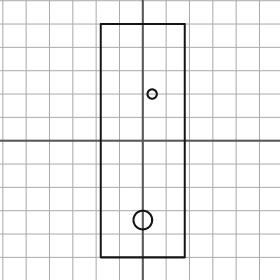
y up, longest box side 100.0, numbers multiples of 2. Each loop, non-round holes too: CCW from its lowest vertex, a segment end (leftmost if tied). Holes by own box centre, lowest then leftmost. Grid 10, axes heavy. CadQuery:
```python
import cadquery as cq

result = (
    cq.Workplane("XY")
    .moveTo(-18.0, -50.0)
    .lineTo(18.0, -50.0)
    .lineTo(18.0, 50.0)
    .lineTo(-18.0, 50.0)
    .close()
    .moveTo(0.0, -34.0)
    .circle(4.0)
    .moveTo(4.0, 20.0)
    .circle(2.0)
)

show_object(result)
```